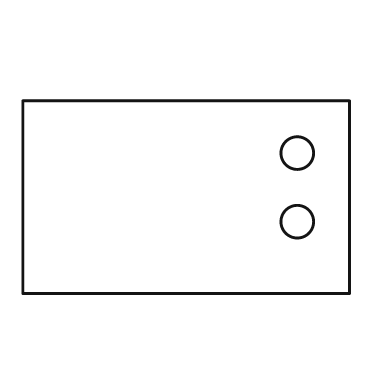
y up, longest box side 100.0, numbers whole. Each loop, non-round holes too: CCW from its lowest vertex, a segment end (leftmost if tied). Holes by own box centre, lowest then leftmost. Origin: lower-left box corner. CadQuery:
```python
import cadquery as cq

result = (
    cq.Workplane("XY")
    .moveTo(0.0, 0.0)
    .lineTo(100.0, 0.0)
    .lineTo(100.0, 59.0)
    .lineTo(0.0, 59.0)
    .close()
    .moveTo(84.0, 22.0)
    .circle(5.0)
    .moveTo(84.0, 43.0)
    .circle(5.0)
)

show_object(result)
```